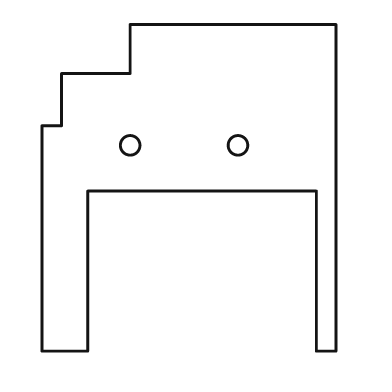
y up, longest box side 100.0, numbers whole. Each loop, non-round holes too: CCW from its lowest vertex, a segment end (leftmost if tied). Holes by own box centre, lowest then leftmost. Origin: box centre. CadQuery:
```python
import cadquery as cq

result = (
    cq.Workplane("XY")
    .moveTo(-45.0, -50.0)
    .lineTo(-31.0, -50.0)
    .lineTo(-31.0, -1.0)
    .lineTo(39.0, -1.0)
    .lineTo(39.0, -50.0)
    .lineTo(45.0, -50.0)
    .lineTo(45.0, 50.0)
    .lineTo(-18.0, 50.0)
    .lineTo(-18.0, 35.0)
    .lineTo(-39.0, 35.0)
    .lineTo(-39.0, 19.0)
    .lineTo(-45.0, 19.0)
    .close()
    .moveTo(-18.0, 13.0)
    .circle(3.0)
    .moveTo(15.0, 13.0)
    .circle(3.0)
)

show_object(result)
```